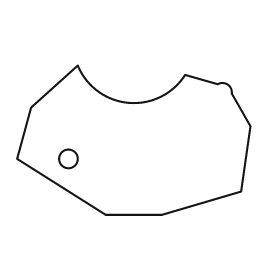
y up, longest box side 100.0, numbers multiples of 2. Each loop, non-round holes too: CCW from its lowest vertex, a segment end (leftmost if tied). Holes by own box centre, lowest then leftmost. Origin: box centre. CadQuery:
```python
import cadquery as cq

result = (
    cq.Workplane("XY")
    .moveTo(-12.0, -32.0)
    .lineTo(12.0, -32.0)
    .lineTo(46.0, -22.0)
    .lineTo(50.0, 6.0)
    .lineTo(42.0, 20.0)
    .threePointArc((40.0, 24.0), (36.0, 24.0))
    .lineTo(22.0, 28.0)
    .threePointArc((-2.0, 16.0), (-24.0, 32.0))
    .lineTo(-44.0, 14.0)
    .lineTo(-50.0, -8.0)
    .close()
    .moveTo(-28.0, -8.0)
    .circle(4.0)
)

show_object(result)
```